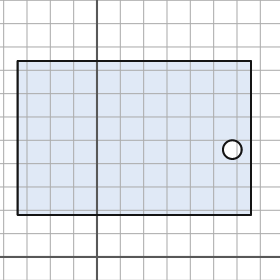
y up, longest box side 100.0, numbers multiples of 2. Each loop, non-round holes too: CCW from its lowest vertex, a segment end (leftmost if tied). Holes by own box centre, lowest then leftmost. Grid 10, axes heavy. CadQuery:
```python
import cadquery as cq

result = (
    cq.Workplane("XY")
    .moveTo(-34.0, 18.0)
    .lineTo(66.0, 18.0)
    .lineTo(66.0, 84.0)
    .lineTo(-34.0, 84.0)
    .close()
    .moveTo(58.0, 46.0)
    .circle(4.0)
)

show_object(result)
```